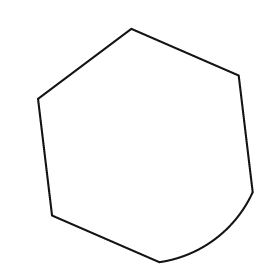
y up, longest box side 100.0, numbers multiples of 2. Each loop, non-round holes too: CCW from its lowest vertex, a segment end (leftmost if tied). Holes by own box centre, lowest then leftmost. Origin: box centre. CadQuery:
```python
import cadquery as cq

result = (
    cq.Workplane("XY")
    .moveTo(6.0, -50.0)
    .threePointArc((30.0, -40.0), (46.0, -20.0))
    .lineTo(40.0, 30.0)
    .lineTo(-6.0, 50.0)
    .lineTo(-46.0, 20.0)
    .lineTo(-40.0, -30.0)
    .close()
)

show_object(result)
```